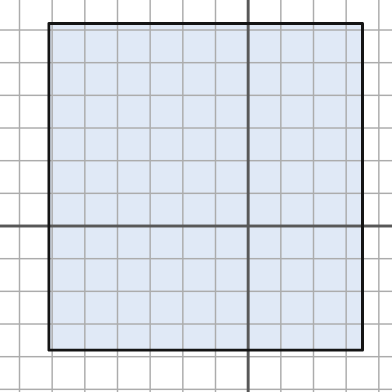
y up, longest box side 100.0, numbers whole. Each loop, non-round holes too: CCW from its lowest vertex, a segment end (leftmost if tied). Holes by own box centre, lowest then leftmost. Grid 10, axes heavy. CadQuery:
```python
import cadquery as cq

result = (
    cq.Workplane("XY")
    .moveTo(-61.0, -38.0)
    .lineTo(35.0, -38.0)
    .lineTo(35.0, 62.0)
    .lineTo(-61.0, 62.0)
    .close()
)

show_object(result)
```